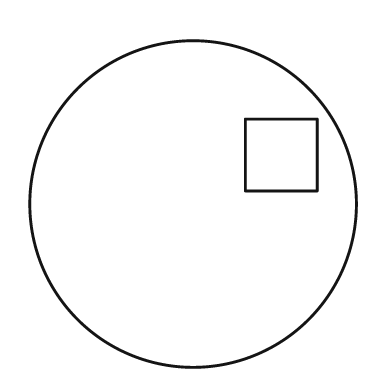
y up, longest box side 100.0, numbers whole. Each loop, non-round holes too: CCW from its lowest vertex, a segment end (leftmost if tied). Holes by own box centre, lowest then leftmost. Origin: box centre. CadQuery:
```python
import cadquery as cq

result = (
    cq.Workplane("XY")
    .moveTo(0.0, 0.0)
    .circle(50.0)
    .moveTo(16.0, 4.0)
    .lineTo(38.0, 4.0)
    .lineTo(38.0, 26.0)
    .lineTo(16.0, 26.0)
    .close()
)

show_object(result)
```